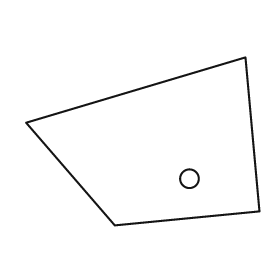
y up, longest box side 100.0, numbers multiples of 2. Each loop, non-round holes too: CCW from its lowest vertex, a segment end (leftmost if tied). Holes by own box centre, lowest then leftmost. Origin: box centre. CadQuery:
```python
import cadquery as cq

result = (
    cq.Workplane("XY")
    .moveTo(-12.0, -36.0)
    .lineTo(50.0, -30.0)
    .lineTo(44.0, 36.0)
    .lineTo(-50.0, 8.0)
    .close()
    .moveTo(20.0, -16.0)
    .circle(4.0)
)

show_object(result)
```